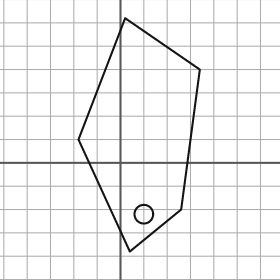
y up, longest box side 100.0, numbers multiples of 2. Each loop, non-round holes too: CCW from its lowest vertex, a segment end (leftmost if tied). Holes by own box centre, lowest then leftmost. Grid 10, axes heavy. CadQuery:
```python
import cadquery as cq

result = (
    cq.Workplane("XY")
    .moveTo(4.0, -38.0)
    .lineTo(26.0, -20.0)
    .lineTo(34.0, 40.0)
    .lineTo(2.0, 62.0)
    .lineTo(-18.0, 10.0)
    .close()
    .moveTo(10.0, -22.0)
    .circle(4.0)
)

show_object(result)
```